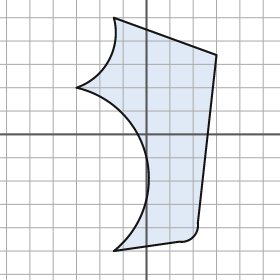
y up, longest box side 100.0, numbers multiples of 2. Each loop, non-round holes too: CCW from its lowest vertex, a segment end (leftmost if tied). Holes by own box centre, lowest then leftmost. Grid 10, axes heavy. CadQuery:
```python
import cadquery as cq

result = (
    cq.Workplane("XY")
    .moveTo(-14.0, -50.0)
    .lineTo(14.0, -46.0)
    .threePointArc((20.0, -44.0), (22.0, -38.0))
    .lineTo(30.0, 34.0)
    .lineTo(-14.0, 50.0)
    .threePointArc((-16.0, 32.0), (-30.0, 20.0))
    .threePointArc((0.0, -10.0), (-14.0, -50.0))
    .close()
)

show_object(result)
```